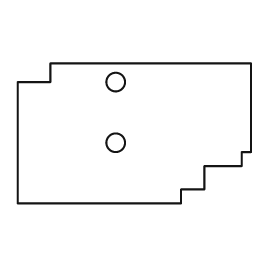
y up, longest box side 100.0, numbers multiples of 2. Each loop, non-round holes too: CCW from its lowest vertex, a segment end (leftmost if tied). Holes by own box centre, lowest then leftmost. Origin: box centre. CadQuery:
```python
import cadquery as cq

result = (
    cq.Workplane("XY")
    .moveTo(-50.0, -30.0)
    .lineTo(20.0, -30.0)
    .lineTo(20.0, -24.0)
    .lineTo(30.0, -24.0)
    .lineTo(30.0, -14.0)
    .lineTo(46.0, -14.0)
    .lineTo(46.0, -8.0)
    .lineTo(50.0, -8.0)
    .lineTo(50.0, 30.0)
    .lineTo(-36.0, 30.0)
    .lineTo(-36.0, 22.0)
    .lineTo(-50.0, 22.0)
    .close()
    .moveTo(-8.0, -4.0)
    .circle(4.0)
    .moveTo(-8.0, 22.0)
    .circle(4.0)
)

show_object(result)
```